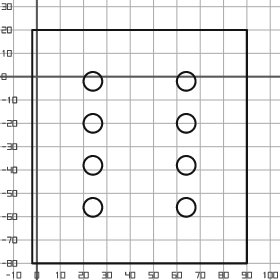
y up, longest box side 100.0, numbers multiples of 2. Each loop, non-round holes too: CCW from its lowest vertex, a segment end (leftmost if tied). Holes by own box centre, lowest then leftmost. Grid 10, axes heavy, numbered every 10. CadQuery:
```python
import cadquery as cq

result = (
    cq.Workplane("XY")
    .moveTo(-2.0, -80.0)
    .lineTo(90.0, -80.0)
    .lineTo(90.0, 20.0)
    .lineTo(-2.0, 20.0)
    .close()
    .moveTo(24.0, -56.0)
    .circle(4.0)
    .moveTo(64.0, -56.0)
    .circle(4.0)
    .moveTo(24.0, -38.0)
    .circle(4.0)
    .moveTo(64.0, -38.0)
    .circle(4.0)
    .moveTo(24.0, -20.0)
    .circle(4.0)
    .moveTo(64.0, -20.0)
    .circle(4.0)
    .moveTo(24.0, -2.0)
    .circle(4.0)
    .moveTo(64.0, -2.0)
    .circle(4.0)
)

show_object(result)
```